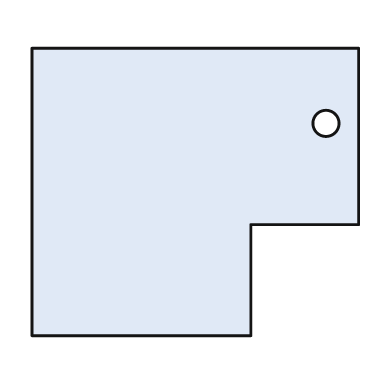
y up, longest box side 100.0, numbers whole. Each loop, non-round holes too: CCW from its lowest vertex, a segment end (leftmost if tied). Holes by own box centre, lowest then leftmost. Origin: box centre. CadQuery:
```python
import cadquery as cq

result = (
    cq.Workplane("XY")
    .moveTo(-50.0, -44.0)
    .lineTo(17.0, -44.0)
    .lineTo(17.0, -10.0)
    .lineTo(50.0, -10.0)
    .lineTo(50.0, 44.0)
    .lineTo(-50.0, 44.0)
    .close()
    .moveTo(40.0, 21.0)
    .circle(4.0)
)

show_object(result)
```